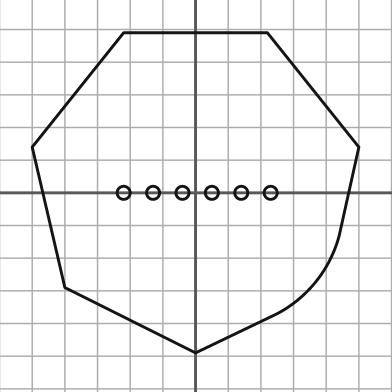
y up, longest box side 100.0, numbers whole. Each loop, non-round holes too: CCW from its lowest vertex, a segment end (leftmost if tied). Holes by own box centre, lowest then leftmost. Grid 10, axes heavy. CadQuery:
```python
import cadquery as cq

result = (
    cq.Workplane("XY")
    .moveTo(0.0, -49.0)
    .lineTo(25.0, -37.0)
    .threePointArc((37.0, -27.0), (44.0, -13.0))
    .lineTo(50.0, 14.0)
    .lineTo(22.0, 49.0)
    .lineTo(-22.0, 49.0)
    .lineTo(-50.0, 14.0)
    .lineTo(-40.0, -29.0)
    .close()
    .moveTo(-22.0, 0.0)
    .circle(2.0)
    .moveTo(-13.0, 0.0)
    .circle(2.0)
    .moveTo(-4.0, 0.0)
    .circle(2.0)
    .moveTo(5.0, 0.0)
    .circle(2.0)
    .moveTo(14.0, 0.0)
    .circle(2.0)
    .moveTo(23.0, 0.0)
    .circle(2.0)
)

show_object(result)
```